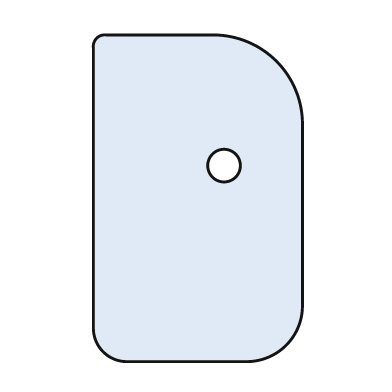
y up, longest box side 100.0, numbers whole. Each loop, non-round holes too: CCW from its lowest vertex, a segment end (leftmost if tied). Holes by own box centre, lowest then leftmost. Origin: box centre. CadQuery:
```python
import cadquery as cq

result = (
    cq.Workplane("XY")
    .moveTo(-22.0, -50.0)
    .lineTo(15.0, -50.0)
    .threePointArc((27.0, -45.0), (32.0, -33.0))
    .lineTo(32.0, 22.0)
    .threePointArc((24.0, 42.0), (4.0, 50.0))
    .lineTo(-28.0, 50.0)
    .threePointArc((-31.0, 49.0), (-32.0, 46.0))
    .lineTo(-32.0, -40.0)
    .threePointArc((-29.0, -47.0), (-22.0, -50.0))
    .close()
    .moveTo(8.0, 10.0)
    .circle(5.0)
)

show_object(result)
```